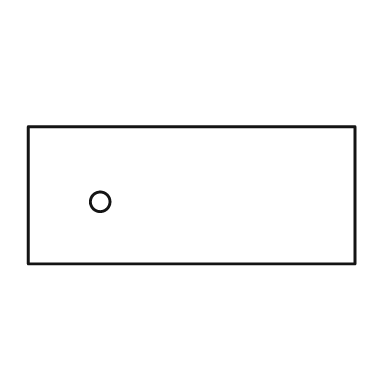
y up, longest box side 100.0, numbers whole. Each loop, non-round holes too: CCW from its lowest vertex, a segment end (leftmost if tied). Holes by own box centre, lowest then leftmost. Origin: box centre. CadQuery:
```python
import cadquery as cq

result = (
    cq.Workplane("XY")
    .moveTo(-50.0, -21.0)
    .lineTo(50.0, -21.0)
    .lineTo(50.0, 21.0)
    .lineTo(-50.0, 21.0)
    .close()
    .moveTo(-28.0, -2.0)
    .circle(3.0)
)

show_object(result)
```